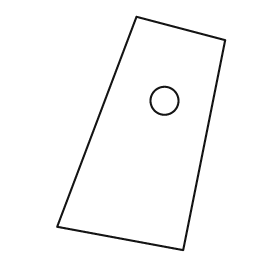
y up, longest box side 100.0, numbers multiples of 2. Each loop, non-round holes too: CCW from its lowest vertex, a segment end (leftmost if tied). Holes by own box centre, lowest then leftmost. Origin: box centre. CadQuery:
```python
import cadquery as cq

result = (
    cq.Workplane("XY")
    .moveTo(18.0, -50.0)
    .lineTo(36.0, 40.0)
    .lineTo(-2.0, 50.0)
    .lineTo(-36.0, -40.0)
    .close()
    .moveTo(10.0, 14.0)
    .circle(6.0)
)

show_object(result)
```